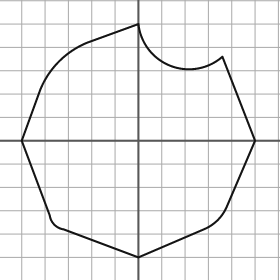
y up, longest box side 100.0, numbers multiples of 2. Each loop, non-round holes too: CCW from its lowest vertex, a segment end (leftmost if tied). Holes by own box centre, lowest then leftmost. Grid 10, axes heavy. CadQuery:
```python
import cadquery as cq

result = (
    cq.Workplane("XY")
    .moveTo(0.0, -50.0)
    .lineTo(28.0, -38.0)
    .threePointArc((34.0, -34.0), (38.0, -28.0))
    .lineTo(50.0, 0.0)
    .lineTo(36.0, 36.0)
    .threePointArc((14.0, 32.0), (0.0, 50.0))
    .lineTo(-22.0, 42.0)
    .threePointArc((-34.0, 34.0), (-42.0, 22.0))
    .lineTo(-50.0, 0.0)
    .lineTo(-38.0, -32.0)
    .threePointArc((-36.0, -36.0), (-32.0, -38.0))
    .close()
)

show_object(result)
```